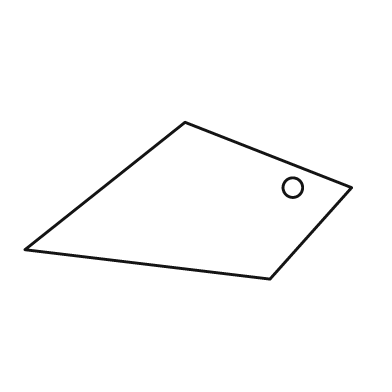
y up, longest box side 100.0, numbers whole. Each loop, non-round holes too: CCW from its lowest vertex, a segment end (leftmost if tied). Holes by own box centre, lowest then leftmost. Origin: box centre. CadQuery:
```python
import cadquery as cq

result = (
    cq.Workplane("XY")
    .moveTo(25.0, -24.0)
    .lineTo(50.0, 4.0)
    .lineTo(-1.0, 24.0)
    .lineTo(-50.0, -15.0)
    .close()
    .moveTo(32.0, 4.0)
    .circle(3.0)
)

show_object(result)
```